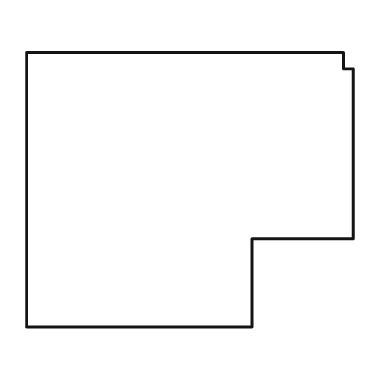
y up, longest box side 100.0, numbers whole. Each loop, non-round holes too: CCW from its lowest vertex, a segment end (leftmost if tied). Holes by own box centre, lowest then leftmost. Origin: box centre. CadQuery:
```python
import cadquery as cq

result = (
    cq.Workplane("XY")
    .moveTo(-50.0, -42.0)
    .lineTo(19.0, -42.0)
    .lineTo(19.0, -15.0)
    .lineTo(50.0, -15.0)
    .lineTo(50.0, 37.0)
    .lineTo(47.0, 37.0)
    .lineTo(47.0, 42.0)
    .lineTo(-50.0, 42.0)
    .close()
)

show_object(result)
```